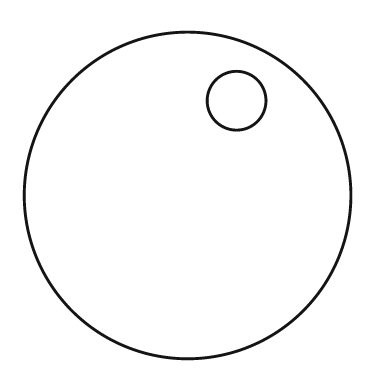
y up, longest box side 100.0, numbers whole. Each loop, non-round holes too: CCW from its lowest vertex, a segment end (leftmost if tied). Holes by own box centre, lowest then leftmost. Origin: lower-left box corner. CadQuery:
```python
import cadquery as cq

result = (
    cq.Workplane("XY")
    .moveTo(50.0, 50.0)
    .circle(50.0)
    .moveTo(65.0, 79.0)
    .circle(9.0)
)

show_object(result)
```